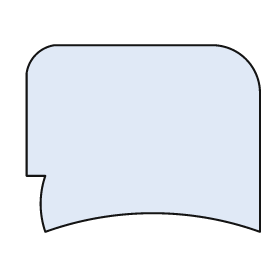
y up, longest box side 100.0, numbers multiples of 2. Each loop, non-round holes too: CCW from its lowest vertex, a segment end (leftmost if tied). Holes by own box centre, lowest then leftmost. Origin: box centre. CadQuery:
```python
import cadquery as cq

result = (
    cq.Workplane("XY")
    .moveTo(-42.0, -40.0)
    .threePointArc((4.0, -32.0), (50.0, -40.0))
    .lineTo(50.0, 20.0)
    .threePointArc((44.0, 34.0), (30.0, 40.0))
    .lineTo(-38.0, 40.0)
    .threePointArc((-46.0, 36.0), (-50.0, 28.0))
    .lineTo(-50.0, -16.0)
    .lineTo(-42.0, -16.0)
    .threePointArc((-44.0, -28.0), (-42.0, -40.0))
    .close()
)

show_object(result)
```